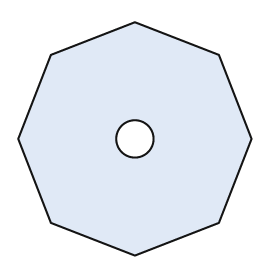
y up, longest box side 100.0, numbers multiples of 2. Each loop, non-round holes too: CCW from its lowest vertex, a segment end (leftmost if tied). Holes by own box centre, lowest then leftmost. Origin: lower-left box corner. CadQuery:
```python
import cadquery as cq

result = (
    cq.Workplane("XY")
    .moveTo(50.0, 0.0)
    .lineTo(86.0, 14.0)
    .lineTo(100.0, 50.0)
    .lineTo(86.0, 86.0)
    .lineTo(50.0, 100.0)
    .lineTo(14.0, 86.0)
    .lineTo(0.0, 50.0)
    .lineTo(14.0, 14.0)
    .close()
    .moveTo(50.0, 50.0)
    .circle(8.0)
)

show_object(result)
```